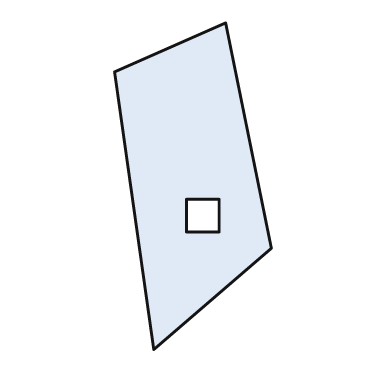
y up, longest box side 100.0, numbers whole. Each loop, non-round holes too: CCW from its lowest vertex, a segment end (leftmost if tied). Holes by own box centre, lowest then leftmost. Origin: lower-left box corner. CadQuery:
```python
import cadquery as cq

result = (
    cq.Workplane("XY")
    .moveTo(12.0, 0.0)
    .lineTo(48.0, 31.0)
    .lineTo(34.0, 100.0)
    .lineTo(0.0, 85.0)
    .close()
    .moveTo(22.0, 36.0)
    .lineTo(32.0, 36.0)
    .lineTo(32.0, 46.0)
    .lineTo(22.0, 46.0)
    .close()
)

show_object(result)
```